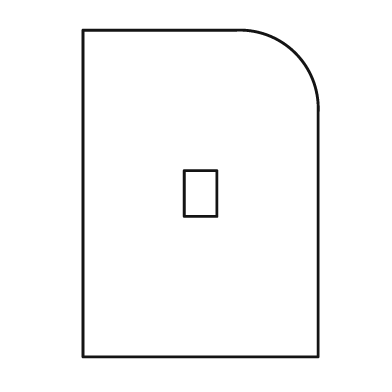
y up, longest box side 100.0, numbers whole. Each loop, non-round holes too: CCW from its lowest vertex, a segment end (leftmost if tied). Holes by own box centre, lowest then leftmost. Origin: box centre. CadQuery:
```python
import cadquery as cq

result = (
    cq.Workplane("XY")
    .moveTo(-36.0, -50.0)
    .lineTo(36.0, -50.0)
    .lineTo(36.0, 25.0)
    .threePointArc((29.0, 43.0), (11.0, 50.0))
    .lineTo(-36.0, 50.0)
    .close()
    .moveTo(-5.0, -7.0)
    .lineTo(5.0, -7.0)
    .lineTo(5.0, 7.0)
    .lineTo(-5.0, 7.0)
    .close()
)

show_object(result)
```